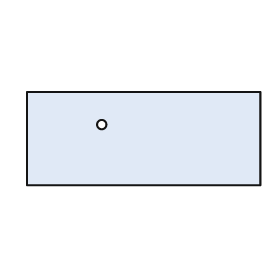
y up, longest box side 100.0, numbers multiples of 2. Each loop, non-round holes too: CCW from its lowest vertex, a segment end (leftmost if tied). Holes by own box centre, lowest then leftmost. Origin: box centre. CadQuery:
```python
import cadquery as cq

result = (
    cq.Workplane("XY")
    .moveTo(-50.0, -20.0)
    .lineTo(50.0, -20.0)
    .lineTo(50.0, 20.0)
    .lineTo(-50.0, 20.0)
    .close()
    .moveTo(-18.0, 6.0)
    .circle(2.0)
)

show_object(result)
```